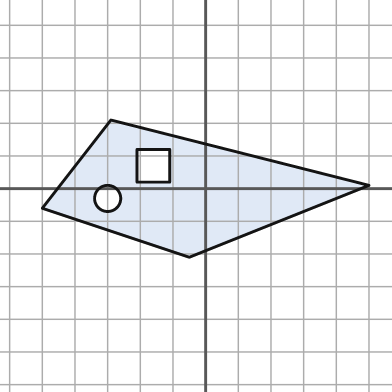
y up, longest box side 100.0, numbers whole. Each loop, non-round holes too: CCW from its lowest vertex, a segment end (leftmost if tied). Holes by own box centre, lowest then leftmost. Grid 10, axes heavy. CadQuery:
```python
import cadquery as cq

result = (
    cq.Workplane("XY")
    .moveTo(-5.0, -21.0)
    .lineTo(50.0, 1.0)
    .lineTo(-29.0, 21.0)
    .lineTo(-50.0, -6.0)
    .close()
    .moveTo(-30.0, -3.0)
    .circle(4.0)
    .moveTo(-21.0, 2.0)
    .lineTo(-11.0, 2.0)
    .lineTo(-11.0, 12.0)
    .lineTo(-21.0, 12.0)
    .close()
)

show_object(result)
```